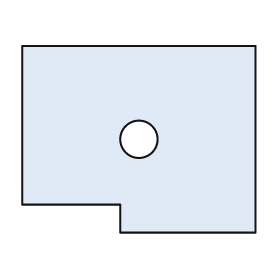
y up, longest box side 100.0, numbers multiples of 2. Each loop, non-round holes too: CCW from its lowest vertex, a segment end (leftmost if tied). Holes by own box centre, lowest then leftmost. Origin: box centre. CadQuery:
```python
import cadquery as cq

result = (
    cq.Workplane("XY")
    .moveTo(-8.0, -40.0)
    .lineTo(50.0, -40.0)
    .lineTo(50.0, 40.0)
    .lineTo(-50.0, 40.0)
    .lineTo(-50.0, -28.0)
    .lineTo(-8.0, -28.0)
    .close()
    .moveTo(0.0, 0.0)
    .circle(8.0)
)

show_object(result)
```